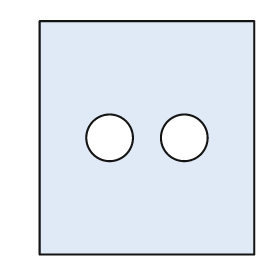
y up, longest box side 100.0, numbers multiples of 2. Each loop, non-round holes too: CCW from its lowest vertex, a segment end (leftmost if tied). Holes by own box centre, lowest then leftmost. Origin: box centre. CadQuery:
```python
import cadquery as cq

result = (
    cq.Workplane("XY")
    .moveTo(-46.0, -50.0)
    .lineTo(46.0, -50.0)
    .lineTo(46.0, 50.0)
    .lineTo(-46.0, 50.0)
    .close()
    .moveTo(-16.0, 0.0)
    .circle(10.0)
    .moveTo(16.0, 0.0)
    .circle(10.0)
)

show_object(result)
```